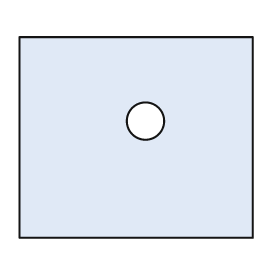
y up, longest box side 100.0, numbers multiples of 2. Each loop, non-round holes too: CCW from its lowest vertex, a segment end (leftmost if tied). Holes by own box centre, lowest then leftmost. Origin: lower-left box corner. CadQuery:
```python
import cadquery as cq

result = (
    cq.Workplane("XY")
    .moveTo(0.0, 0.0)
    .lineTo(100.0, 0.0)
    .lineTo(100.0, 86.0)
    .lineTo(0.0, 86.0)
    .close()
    .moveTo(54.0, 50.0)
    .circle(8.0)
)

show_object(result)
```